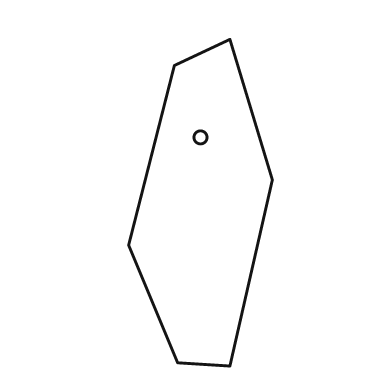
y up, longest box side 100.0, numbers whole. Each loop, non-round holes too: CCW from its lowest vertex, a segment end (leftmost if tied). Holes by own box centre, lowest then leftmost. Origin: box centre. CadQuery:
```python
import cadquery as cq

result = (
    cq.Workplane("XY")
    .moveTo(9.0, -50.0)
    .lineTo(22.0, 7.0)
    .lineTo(9.0, 50.0)
    .lineTo(-8.0, 42.0)
    .lineTo(-22.0, -13.0)
    .lineTo(-7.0, -49.0)
    .close()
    .moveTo(0.0, 20.0)
    .circle(2.0)
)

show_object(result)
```